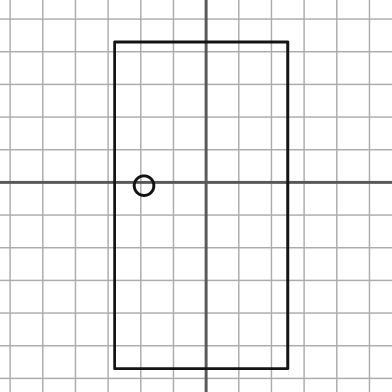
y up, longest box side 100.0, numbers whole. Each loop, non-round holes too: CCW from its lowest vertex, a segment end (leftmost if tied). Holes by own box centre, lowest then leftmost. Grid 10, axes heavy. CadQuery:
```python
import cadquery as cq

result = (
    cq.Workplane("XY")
    .moveTo(-28.0, -57.0)
    .lineTo(25.0, -57.0)
    .lineTo(25.0, 43.0)
    .lineTo(-28.0, 43.0)
    .close()
    .moveTo(-19.0, -1.0)
    .circle(3.0)
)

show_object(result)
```